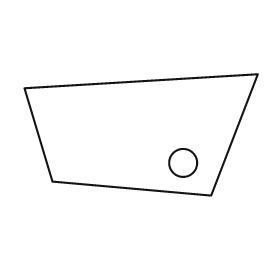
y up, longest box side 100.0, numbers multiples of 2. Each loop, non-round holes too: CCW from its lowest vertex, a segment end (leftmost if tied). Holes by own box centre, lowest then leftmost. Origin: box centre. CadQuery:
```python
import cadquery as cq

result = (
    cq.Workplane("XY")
    .moveTo(30.0, -26.0)
    .lineTo(50.0, 26.0)
    .lineTo(-50.0, 20.0)
    .lineTo(-38.0, -20.0)
    .close()
    .moveTo(18.0, -12.0)
    .circle(6.0)
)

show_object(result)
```